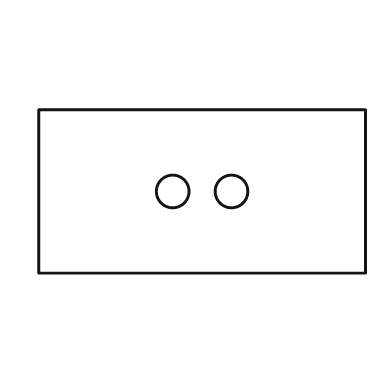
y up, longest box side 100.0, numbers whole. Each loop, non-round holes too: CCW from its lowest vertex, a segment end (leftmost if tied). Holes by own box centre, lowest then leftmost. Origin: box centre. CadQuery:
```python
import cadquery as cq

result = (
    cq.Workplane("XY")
    .moveTo(-50.0, -25.0)
    .lineTo(50.0, -25.0)
    .lineTo(50.0, 25.0)
    .lineTo(-50.0, 25.0)
    .close()
    .moveTo(-9.0, 0.0)
    .circle(5.0)
    .moveTo(9.0, 0.0)
    .circle(5.0)
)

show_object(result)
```